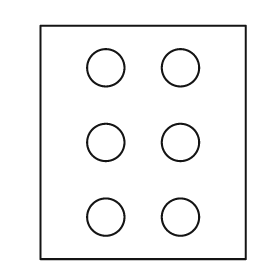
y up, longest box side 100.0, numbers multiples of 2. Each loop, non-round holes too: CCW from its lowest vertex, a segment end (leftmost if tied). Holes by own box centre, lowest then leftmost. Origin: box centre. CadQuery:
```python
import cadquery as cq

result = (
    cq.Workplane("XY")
    .moveTo(-44.0, -50.0)
    .lineTo(44.0, -50.0)
    .lineTo(44.0, 50.0)
    .lineTo(-44.0, 50.0)
    .close()
    .moveTo(-16.0, -32.0)
    .circle(8.0)
    .moveTo(16.0, -32.0)
    .circle(8.0)
    .moveTo(-16.0, 0.0)
    .circle(8.0)
    .moveTo(16.0, 0.0)
    .circle(8.0)
    .moveTo(-16.0, 32.0)
    .circle(8.0)
    .moveTo(16.0, 32.0)
    .circle(8.0)
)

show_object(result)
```